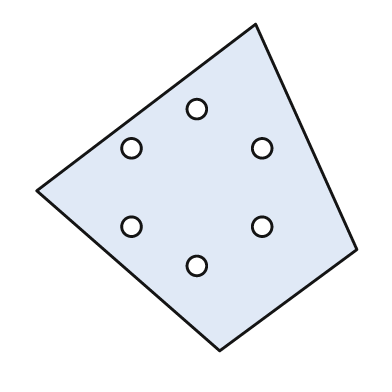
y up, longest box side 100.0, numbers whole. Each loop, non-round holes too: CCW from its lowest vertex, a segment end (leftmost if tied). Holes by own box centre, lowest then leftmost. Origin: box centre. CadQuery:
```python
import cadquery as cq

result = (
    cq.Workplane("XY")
    .moveTo(7.0, -50.0)
    .lineTo(49.0, -19.0)
    .lineTo(18.0, 50.0)
    .lineTo(-49.0, -1.0)
    .close()
    .moveTo(0.0, -24.0)
    .circle(3.0)
    .moveTo(-20.0, -12.0)
    .circle(3.0)
    .moveTo(20.0, -12.0)
    .circle(3.0)
    .moveTo(-20.0, 12.0)
    .circle(3.0)
    .moveTo(20.0, 12.0)
    .circle(3.0)
    .moveTo(0.0, 24.0)
    .circle(3.0)
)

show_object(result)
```